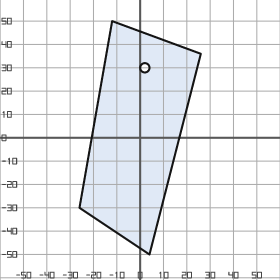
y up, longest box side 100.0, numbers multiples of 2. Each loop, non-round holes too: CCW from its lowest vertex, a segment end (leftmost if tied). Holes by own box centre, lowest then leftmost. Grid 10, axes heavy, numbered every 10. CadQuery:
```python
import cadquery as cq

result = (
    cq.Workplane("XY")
    .moveTo(4.0, -50.0)
    .lineTo(26.0, 36.0)
    .lineTo(-12.0, 50.0)
    .lineTo(-26.0, -30.0)
    .close()
    .moveTo(2.0, 30.0)
    .circle(2.0)
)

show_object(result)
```